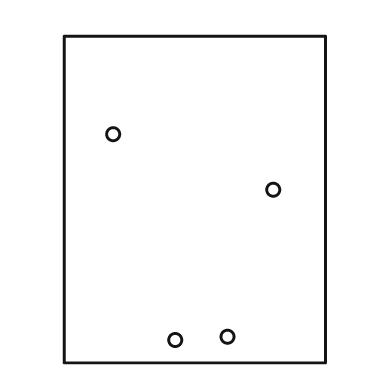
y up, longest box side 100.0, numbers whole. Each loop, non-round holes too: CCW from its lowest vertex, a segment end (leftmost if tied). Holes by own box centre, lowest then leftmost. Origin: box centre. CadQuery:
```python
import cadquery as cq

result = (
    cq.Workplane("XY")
    .moveTo(-40.0, -50.0)
    .lineTo(40.0, -50.0)
    .lineTo(40.0, 50.0)
    .lineTo(-40.0, 50.0)
    .close()
    .moveTo(-6.0, -43.0)
    .circle(2.0)
    .moveTo(10.0, -42.0)
    .circle(2.0)
    .moveTo(24.0, 3.0)
    .circle(2.0)
    .moveTo(-25.0, 20.0)
    .circle(2.0)
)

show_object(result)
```